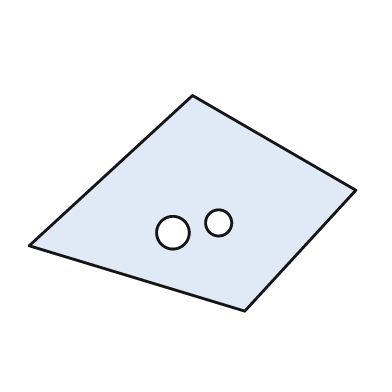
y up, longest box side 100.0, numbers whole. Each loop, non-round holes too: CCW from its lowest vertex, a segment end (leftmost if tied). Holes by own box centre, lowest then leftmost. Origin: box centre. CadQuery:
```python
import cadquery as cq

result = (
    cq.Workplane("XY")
    .moveTo(16.0, -33.0)
    .lineTo(50.0, 4.0)
    .lineTo(0.0, 33.0)
    .lineTo(-50.0, -13.0)
    .close()
    .moveTo(-6.0, -9.0)
    .circle(5.0)
    .moveTo(8.0, -6.0)
    .circle(4.0)
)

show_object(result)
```